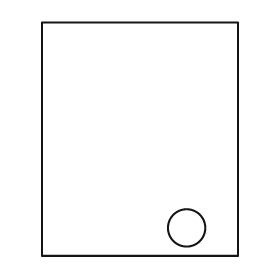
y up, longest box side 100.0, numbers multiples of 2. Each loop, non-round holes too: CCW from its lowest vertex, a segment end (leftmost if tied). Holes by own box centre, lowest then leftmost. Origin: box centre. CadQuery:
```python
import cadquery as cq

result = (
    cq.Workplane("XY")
    .moveTo(-42.0, -50.0)
    .lineTo(42.0, -50.0)
    .lineTo(42.0, 50.0)
    .lineTo(-42.0, 50.0)
    .close()
    .moveTo(20.0, -38.0)
    .circle(8.0)
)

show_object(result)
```